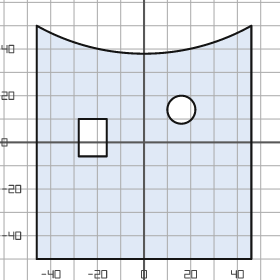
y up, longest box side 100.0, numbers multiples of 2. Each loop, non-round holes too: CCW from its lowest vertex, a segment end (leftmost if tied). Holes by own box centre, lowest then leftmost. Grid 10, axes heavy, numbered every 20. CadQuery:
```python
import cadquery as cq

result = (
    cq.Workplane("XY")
    .moveTo(-46.0, -50.0)
    .lineTo(46.0, -50.0)
    .lineTo(46.0, 50.0)
    .threePointArc((0.0, 38.0), (-46.0, 50.0))
    .close()
    .moveTo(-28.0, -6.0)
    .lineTo(-16.0, -6.0)
    .lineTo(-16.0, 10.0)
    .lineTo(-28.0, 10.0)
    .close()
    .moveTo(16.0, 14.0)
    .circle(6.0)
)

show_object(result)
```